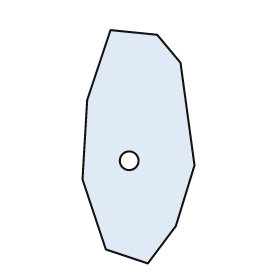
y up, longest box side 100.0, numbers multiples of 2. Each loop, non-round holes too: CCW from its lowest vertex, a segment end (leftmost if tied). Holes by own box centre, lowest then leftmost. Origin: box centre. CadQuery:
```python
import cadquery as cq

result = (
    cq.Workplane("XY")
    .moveTo(4.0, -50.0)
    .lineTo(16.0, -34.0)
    .lineTo(24.0, -8.0)
    .lineTo(18.0, 36.0)
    .lineTo(8.0, 48.0)
    .lineTo(-12.0, 50.0)
    .lineTo(-22.0, 20.0)
    .lineTo(-24.0, -14.0)
    .lineTo(-14.0, -44.0)
    .close()
    .moveTo(-4.0, -6.0)
    .circle(4.0)
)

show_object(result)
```